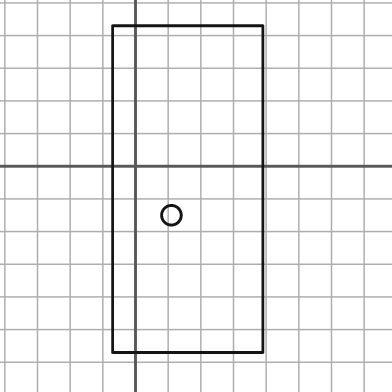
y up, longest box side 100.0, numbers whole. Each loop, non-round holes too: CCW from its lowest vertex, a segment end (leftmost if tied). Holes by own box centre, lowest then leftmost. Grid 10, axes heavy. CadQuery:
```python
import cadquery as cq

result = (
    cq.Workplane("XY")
    .moveTo(-7.0, -57.0)
    .lineTo(39.0, -57.0)
    .lineTo(39.0, 43.0)
    .lineTo(-7.0, 43.0)
    .close()
    .moveTo(11.0, -15.0)
    .circle(3.0)
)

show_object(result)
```